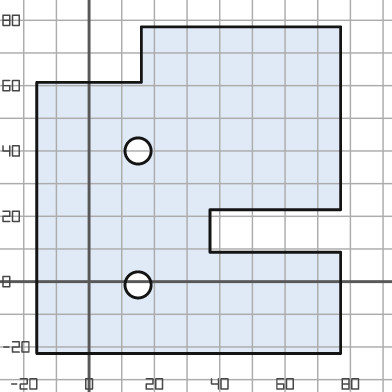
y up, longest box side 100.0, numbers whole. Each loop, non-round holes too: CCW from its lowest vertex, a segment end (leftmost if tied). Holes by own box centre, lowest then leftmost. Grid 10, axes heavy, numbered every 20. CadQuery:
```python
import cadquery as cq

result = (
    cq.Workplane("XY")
    .moveTo(-16.0, -22.0)
    .lineTo(77.0, -22.0)
    .lineTo(77.0, 9.0)
    .lineTo(37.0, 9.0)
    .lineTo(37.0, 22.0)
    .lineTo(77.0, 22.0)
    .lineTo(77.0, 78.0)
    .lineTo(16.0, 78.0)
    .lineTo(16.0, 61.0)
    .lineTo(-16.0, 61.0)
    .close()
    .moveTo(15.0, -1.0)
    .circle(4.0)
    .moveTo(15.0, 40.0)
    .circle(4.0)
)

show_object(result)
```